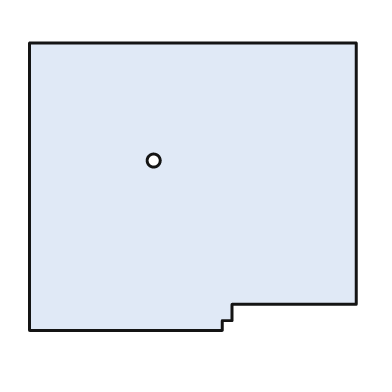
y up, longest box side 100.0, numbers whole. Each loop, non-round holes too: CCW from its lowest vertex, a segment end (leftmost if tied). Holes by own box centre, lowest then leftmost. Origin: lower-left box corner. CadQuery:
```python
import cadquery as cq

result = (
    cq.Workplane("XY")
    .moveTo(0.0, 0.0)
    .lineTo(59.0, 0.0)
    .lineTo(59.0, 3.0)
    .lineTo(62.0, 3.0)
    .lineTo(62.0, 8.0)
    .lineTo(100.0, 8.0)
    .lineTo(100.0, 88.0)
    .lineTo(0.0, 88.0)
    .close()
    .moveTo(38.0, 52.0)
    .circle(2.0)
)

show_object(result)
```